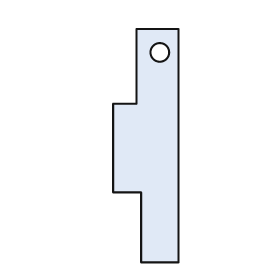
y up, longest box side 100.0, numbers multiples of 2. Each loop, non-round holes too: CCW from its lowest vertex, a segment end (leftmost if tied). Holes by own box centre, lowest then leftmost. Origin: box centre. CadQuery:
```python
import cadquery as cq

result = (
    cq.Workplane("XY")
    .moveTo(-2.0, -50.0)
    .lineTo(14.0, -50.0)
    .lineTo(14.0, 50.0)
    .lineTo(-4.0, 50.0)
    .lineTo(-4.0, 18.0)
    .lineTo(-14.0, 18.0)
    .lineTo(-14.0, -20.0)
    .lineTo(-2.0, -20.0)
    .close()
    .moveTo(6.0, 40.0)
    .circle(4.0)
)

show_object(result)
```